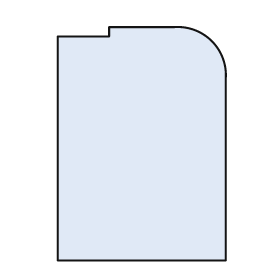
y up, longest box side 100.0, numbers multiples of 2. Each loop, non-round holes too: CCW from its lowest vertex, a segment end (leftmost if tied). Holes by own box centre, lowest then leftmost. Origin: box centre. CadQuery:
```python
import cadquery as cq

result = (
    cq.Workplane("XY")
    .moveTo(-36.0, -50.0)
    .lineTo(36.0, -50.0)
    .lineTo(36.0, 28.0)
    .threePointArc((30.0, 44.0), (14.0, 50.0))
    .lineTo(-14.0, 50.0)
    .lineTo(-14.0, 46.0)
    .lineTo(-36.0, 46.0)
    .close()
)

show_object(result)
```